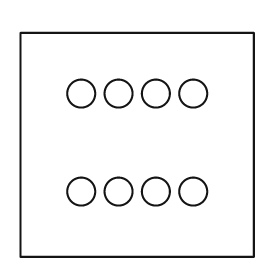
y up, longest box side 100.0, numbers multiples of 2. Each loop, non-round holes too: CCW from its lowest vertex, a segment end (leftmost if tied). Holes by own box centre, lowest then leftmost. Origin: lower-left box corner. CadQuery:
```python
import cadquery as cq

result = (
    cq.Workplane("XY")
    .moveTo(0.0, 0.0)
    .lineTo(100.0, 0.0)
    .lineTo(100.0, 96.0)
    .lineTo(0.0, 96.0)
    .close()
    .moveTo(26.0, 28.0)
    .circle(6.0)
    .moveTo(42.0, 28.0)
    .circle(6.0)
    .moveTo(58.0, 28.0)
    .circle(6.0)
    .moveTo(74.0, 28.0)
    .circle(6.0)
    .moveTo(26.0, 70.0)
    .circle(6.0)
    .moveTo(42.0, 70.0)
    .circle(6.0)
    .moveTo(58.0, 70.0)
    .circle(6.0)
    .moveTo(74.0, 70.0)
    .circle(6.0)
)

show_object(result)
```